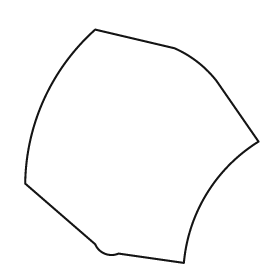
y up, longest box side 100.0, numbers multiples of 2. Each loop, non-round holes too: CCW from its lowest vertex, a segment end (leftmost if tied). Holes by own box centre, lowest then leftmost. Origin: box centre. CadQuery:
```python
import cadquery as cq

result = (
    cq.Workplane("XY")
    .moveTo(18.0, -50.0)
    .threePointArc((28.0, -20.0), (50.0, 2.0))
    .lineTo(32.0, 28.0)
    .threePointArc((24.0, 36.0), (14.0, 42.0))
    .lineTo(-20.0, 50.0)
    .threePointArc((-42.0, 20.0), (-50.0, -16.0))
    .lineTo(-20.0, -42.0)
    .threePointArc((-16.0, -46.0), (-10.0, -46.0))
    .close()
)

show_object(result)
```